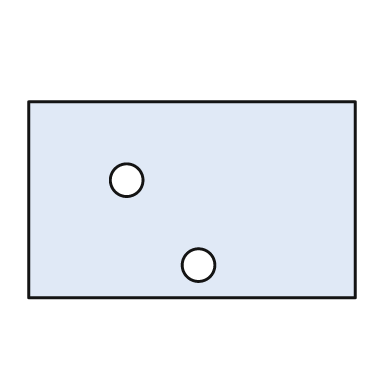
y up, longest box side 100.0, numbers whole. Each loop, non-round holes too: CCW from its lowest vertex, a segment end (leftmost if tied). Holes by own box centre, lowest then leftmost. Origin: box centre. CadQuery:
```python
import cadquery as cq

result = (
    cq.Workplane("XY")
    .moveTo(-50.0, -30.0)
    .lineTo(50.0, -30.0)
    .lineTo(50.0, 30.0)
    .lineTo(-50.0, 30.0)
    .close()
    .moveTo(2.0, -20.0)
    .circle(5.0)
    .moveTo(-20.0, 6.0)
    .circle(5.0)
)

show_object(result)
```